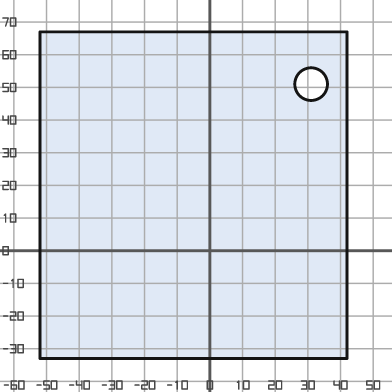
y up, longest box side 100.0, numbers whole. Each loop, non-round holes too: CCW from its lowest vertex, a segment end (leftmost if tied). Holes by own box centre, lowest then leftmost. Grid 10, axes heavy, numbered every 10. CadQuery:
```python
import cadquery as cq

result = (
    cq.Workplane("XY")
    .moveTo(-52.0, -33.0)
    .lineTo(42.0, -33.0)
    .lineTo(42.0, 67.0)
    .lineTo(-52.0, 67.0)
    .close()
    .moveTo(31.0, 51.0)
    .circle(5.0)
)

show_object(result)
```